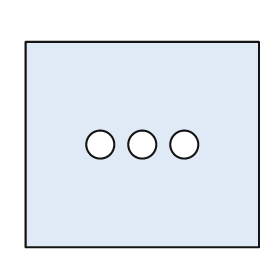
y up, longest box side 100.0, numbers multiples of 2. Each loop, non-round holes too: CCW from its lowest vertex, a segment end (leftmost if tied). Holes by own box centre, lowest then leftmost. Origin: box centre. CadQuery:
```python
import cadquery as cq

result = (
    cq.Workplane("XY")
    .moveTo(-50.0, -44.0)
    .lineTo(50.0, -44.0)
    .lineTo(50.0, 44.0)
    .lineTo(-50.0, 44.0)
    .close()
    .moveTo(-18.0, 0.0)
    .circle(6.0)
    .moveTo(0.0, 0.0)
    .circle(6.0)
    .moveTo(18.0, 0.0)
    .circle(6.0)
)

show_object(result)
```